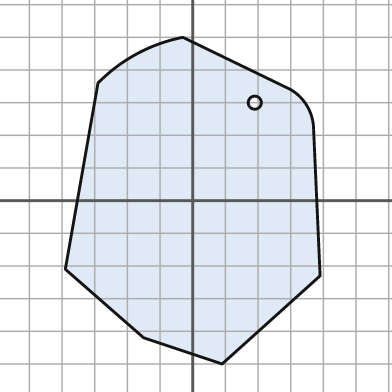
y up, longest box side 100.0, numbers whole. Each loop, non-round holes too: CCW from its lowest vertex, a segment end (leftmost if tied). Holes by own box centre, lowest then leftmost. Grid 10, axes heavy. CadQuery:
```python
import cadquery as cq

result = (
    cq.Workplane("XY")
    .moveTo(9.0, -50.0)
    .lineTo(39.0, -23.0)
    .lineTo(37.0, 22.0)
    .threePointArc((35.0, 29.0), (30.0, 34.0))
    .lineTo(-3.0, 50.0)
    .threePointArc((-17.0, 45.0), (-29.0, 36.0))
    .lineTo(-39.0, -21.0)
    .lineTo(-15.0, -42.0)
    .close()
    .moveTo(19.0, 30.0)
    .circle(2.0)
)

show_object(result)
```